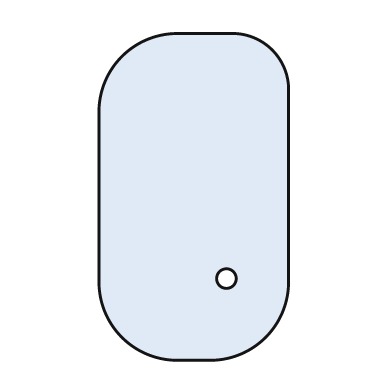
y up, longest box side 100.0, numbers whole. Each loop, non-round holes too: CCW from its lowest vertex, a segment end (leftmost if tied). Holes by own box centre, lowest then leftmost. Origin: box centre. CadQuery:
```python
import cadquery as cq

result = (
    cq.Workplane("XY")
    .moveTo(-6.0, -50.0)
    .lineTo(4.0, -50.0)
    .threePointArc((22.0, -43.0), (29.0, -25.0))
    .lineTo(29.0, 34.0)
    .threePointArc((24.0, 45.0), (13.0, 50.0))
    .lineTo(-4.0, 50.0)
    .threePointArc((-22.0, 43.0), (-29.0, 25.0))
    .lineTo(-29.0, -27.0)
    .threePointArc((-22.0, -43.0), (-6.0, -50.0))
    .close()
    .moveTo(10.0, -25.0)
    .circle(3.0)
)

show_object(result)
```